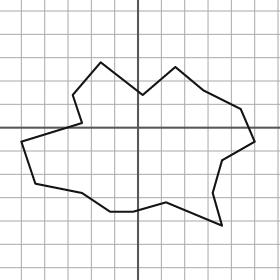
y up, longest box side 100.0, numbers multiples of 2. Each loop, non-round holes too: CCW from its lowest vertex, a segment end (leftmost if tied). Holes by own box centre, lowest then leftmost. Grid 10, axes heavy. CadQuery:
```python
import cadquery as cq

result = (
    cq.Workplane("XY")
    .moveTo(36.0, -42.0)
    .lineTo(32.0, -28.0)
    .lineTo(36.0, -14.0)
    .lineTo(50.0, -6.0)
    .lineTo(44.0, 8.0)
    .lineTo(28.0, 16.0)
    .lineTo(16.0, 26.0)
    .lineTo(2.0, 14.0)
    .lineTo(-16.0, 28.0)
    .lineTo(-28.0, 14.0)
    .lineTo(-24.0, 2.0)
    .lineTo(-50.0, -6.0)
    .lineTo(-44.0, -24.0)
    .lineTo(-24.0, -28.0)
    .lineTo(-12.0, -36.0)
    .lineTo(-2.0, -36.0)
    .lineTo(12.0, -32.0)
    .close()
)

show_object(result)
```